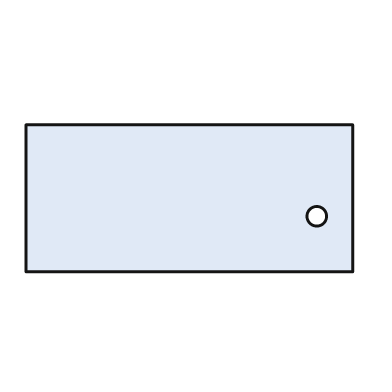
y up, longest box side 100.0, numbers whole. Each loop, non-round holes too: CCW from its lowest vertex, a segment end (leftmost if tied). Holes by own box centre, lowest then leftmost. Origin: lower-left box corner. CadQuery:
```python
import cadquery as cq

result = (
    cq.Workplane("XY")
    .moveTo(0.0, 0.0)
    .lineTo(100.0, 0.0)
    .lineTo(100.0, 45.0)
    .lineTo(0.0, 45.0)
    .close()
    .moveTo(89.0, 17.0)
    .circle(3.0)
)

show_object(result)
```